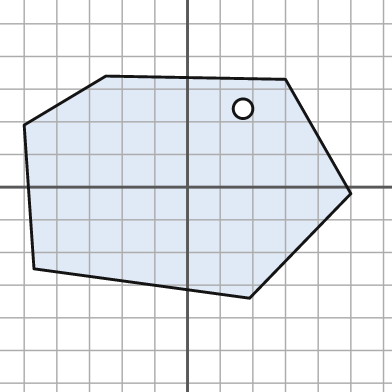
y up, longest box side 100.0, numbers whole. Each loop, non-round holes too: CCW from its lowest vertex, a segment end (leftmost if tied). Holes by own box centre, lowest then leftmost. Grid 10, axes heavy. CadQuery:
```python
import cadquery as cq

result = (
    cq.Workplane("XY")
    .moveTo(19.0, -34.0)
    .lineTo(50.0, -2.0)
    .lineTo(30.0, 33.0)
    .lineTo(-25.0, 34.0)
    .lineTo(-50.0, 19.0)
    .lineTo(-47.0, -25.0)
    .close()
    .moveTo(17.0, 24.0)
    .circle(3.0)
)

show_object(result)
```